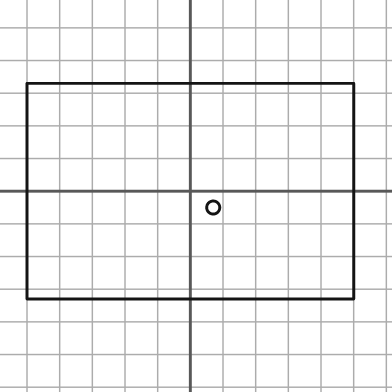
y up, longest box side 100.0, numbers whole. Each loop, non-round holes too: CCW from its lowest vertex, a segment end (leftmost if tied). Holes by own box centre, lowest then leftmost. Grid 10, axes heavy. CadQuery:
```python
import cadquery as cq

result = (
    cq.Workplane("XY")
    .moveTo(-50.0, -33.0)
    .lineTo(50.0, -33.0)
    .lineTo(50.0, 33.0)
    .lineTo(-50.0, 33.0)
    .close()
    .moveTo(7.0, -5.0)
    .circle(2.0)
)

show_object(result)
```